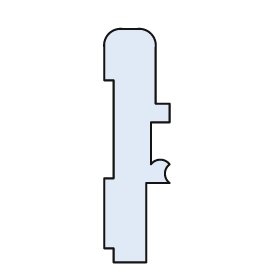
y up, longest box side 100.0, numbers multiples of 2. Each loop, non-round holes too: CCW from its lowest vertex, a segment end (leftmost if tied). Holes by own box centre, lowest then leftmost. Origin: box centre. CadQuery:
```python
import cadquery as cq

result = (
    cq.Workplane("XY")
    .moveTo(-10.0, -50.0)
    .lineTo(4.0, -50.0)
    .lineTo(4.0, -16.0)
    .lineTo(14.0, -16.0)
    .threePointArc((12.0, -12.0), (14.0, -8.0))
    .threePointArc((10.0, -6.0), (6.0, -8.0))
    .lineTo(6.0, 10.0)
    .lineTo(14.0, 10.0)
    .lineTo(14.0, 18.0)
    .lineTo(8.0, 18.0)
    .lineTo(8.0, 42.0)
    .threePointArc((6.0, 48.0), (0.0, 50.0))
    .lineTo(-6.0, 50.0)
    .threePointArc((-12.0, 48.0), (-14.0, 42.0))
    .lineTo(-14.0, 28.0)
    .lineTo(-10.0, 28.0)
    .lineTo(-10.0, -14.0)
    .lineTo(-14.0, -14.0)
    .lineTo(-14.0, -44.0)
    .lineTo(-10.0, -44.0)
    .close()
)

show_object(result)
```